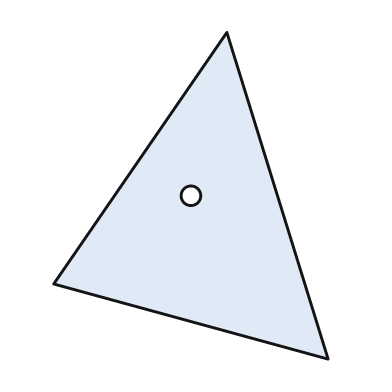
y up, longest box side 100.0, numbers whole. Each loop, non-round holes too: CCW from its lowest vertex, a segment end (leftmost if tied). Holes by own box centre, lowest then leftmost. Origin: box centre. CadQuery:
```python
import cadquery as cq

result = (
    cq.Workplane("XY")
    .moveTo(42.0, -50.0)
    .lineTo(11.0, 50.0)
    .lineTo(-42.0, -27.0)
    .close()
    .moveTo(0.0, 0.0)
    .circle(3.0)
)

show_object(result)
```